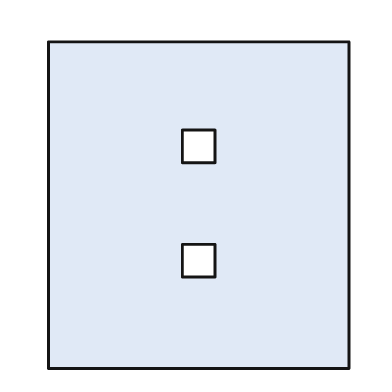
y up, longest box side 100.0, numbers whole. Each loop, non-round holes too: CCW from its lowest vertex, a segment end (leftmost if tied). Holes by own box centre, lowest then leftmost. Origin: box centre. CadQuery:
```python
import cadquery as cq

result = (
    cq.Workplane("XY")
    .moveTo(-46.0, -50.0)
    .lineTo(46.0, -50.0)
    .lineTo(46.0, 50.0)
    .lineTo(-46.0, 50.0)
    .close()
    .moveTo(-5.0, -22.0)
    .lineTo(5.0, -22.0)
    .lineTo(5.0, -12.0)
    .lineTo(-5.0, -12.0)
    .close()
    .moveTo(-5.0, 13.0)
    .lineTo(5.0, 13.0)
    .lineTo(5.0, 23.0)
    .lineTo(-5.0, 23.0)
    .close()
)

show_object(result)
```